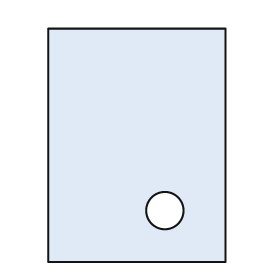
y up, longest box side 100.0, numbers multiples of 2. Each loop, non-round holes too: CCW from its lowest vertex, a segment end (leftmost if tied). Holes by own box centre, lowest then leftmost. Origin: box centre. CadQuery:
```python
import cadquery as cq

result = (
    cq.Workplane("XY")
    .moveTo(-38.0, -50.0)
    .lineTo(38.0, -50.0)
    .lineTo(38.0, 50.0)
    .lineTo(-38.0, 50.0)
    .close()
    .moveTo(12.0, -28.0)
    .circle(8.0)
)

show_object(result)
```